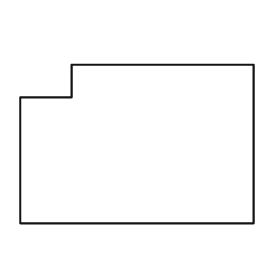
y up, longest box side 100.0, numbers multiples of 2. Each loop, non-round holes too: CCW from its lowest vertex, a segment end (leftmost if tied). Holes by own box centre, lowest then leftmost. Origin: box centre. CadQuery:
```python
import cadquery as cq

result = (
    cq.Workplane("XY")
    .moveTo(-50.0, -34.0)
    .lineTo(50.0, -34.0)
    .lineTo(50.0, 34.0)
    .lineTo(-28.0, 34.0)
    .lineTo(-28.0, 20.0)
    .lineTo(-50.0, 20.0)
    .close()
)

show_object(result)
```